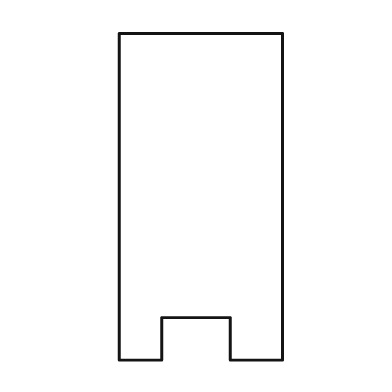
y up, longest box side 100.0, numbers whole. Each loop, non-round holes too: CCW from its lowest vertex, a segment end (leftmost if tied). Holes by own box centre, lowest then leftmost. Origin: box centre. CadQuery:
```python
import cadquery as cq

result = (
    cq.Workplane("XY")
    .moveTo(-25.0, -50.0)
    .lineTo(-12.0, -50.0)
    .lineTo(-12.0, -37.0)
    .lineTo(9.0, -37.0)
    .lineTo(9.0, -50.0)
    .lineTo(25.0, -50.0)
    .lineTo(25.0, 50.0)
    .lineTo(-25.0, 50.0)
    .close()
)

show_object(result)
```